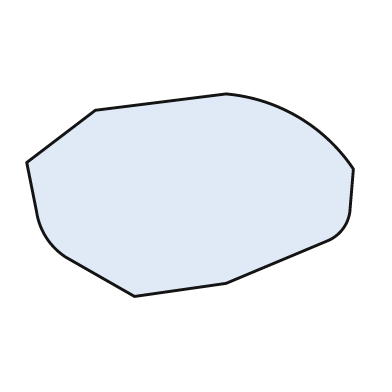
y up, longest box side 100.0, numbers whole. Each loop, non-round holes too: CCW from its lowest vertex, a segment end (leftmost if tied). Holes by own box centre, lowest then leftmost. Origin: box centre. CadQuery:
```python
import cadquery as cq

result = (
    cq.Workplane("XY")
    .moveTo(-17.0, -31.0)
    .lineTo(11.0, -27.0)
    .lineTo(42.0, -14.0)
    .threePointArc((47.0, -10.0), (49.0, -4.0))
    .lineTo(50.0, 8.0)
    .threePointArc((33.0, 24.0), (11.0, 31.0))
    .lineTo(-29.0, 26.0)
    .lineTo(-50.0, 10.0)
    .lineTo(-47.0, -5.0)
    .threePointArc((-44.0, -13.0), (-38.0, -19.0))
    .close()
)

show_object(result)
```